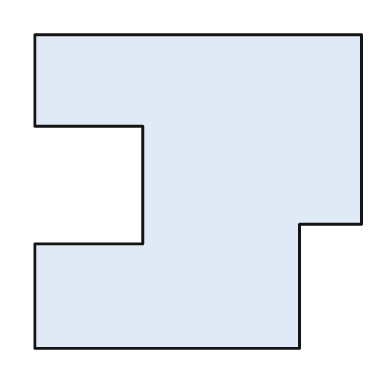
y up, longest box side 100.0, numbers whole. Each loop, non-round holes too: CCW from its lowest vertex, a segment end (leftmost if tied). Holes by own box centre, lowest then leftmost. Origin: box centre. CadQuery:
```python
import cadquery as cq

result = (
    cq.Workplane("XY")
    .moveTo(-50.0, -48.0)
    .lineTo(31.0, -48.0)
    .lineTo(31.0, -10.0)
    .lineTo(50.0, -10.0)
    .lineTo(50.0, 48.0)
    .lineTo(-50.0, 48.0)
    .lineTo(-50.0, 20.0)
    .lineTo(-17.0, 20.0)
    .lineTo(-17.0, -16.0)
    .lineTo(-50.0, -16.0)
    .close()
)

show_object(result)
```